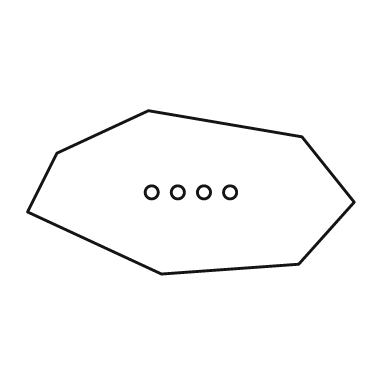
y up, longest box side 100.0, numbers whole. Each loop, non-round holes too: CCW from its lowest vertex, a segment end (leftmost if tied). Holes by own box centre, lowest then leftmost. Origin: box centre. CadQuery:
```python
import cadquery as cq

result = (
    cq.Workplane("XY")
    .moveTo(-9.0, -25.0)
    .lineTo(33.0, -22.0)
    .lineTo(50.0, -3.0)
    .lineTo(34.0, 17.0)
    .lineTo(-13.0, 25.0)
    .lineTo(-41.0, 12.0)
    .lineTo(-50.0, -6.0)
    .close()
    .moveTo(-12.0, 0.0)
    .circle(2.0)
    .moveTo(-4.0, 0.0)
    .circle(2.0)
    .moveTo(4.0, 0.0)
    .circle(2.0)
    .moveTo(12.0, 0.0)
    .circle(2.0)
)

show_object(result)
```